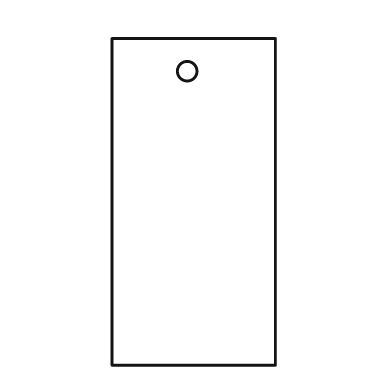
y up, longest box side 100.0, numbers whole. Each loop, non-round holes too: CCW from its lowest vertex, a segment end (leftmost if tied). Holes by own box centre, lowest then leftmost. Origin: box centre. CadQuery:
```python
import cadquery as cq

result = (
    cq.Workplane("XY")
    .moveTo(-25.0, -50.0)
    .lineTo(25.0, -50.0)
    .lineTo(25.0, 50.0)
    .lineTo(-25.0, 50.0)
    .close()
    .moveTo(-2.0, 40.0)
    .circle(3.0)
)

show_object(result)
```